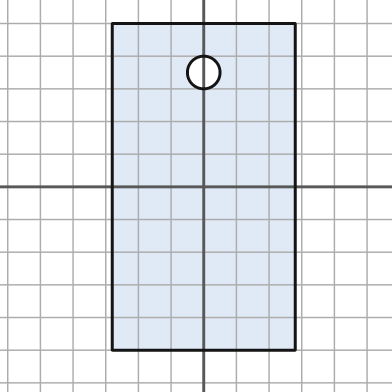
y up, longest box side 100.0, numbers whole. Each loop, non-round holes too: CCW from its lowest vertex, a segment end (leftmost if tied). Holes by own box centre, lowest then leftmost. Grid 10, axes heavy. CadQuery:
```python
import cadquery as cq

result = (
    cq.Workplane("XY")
    .moveTo(-28.0, -50.0)
    .lineTo(28.0, -50.0)
    .lineTo(28.0, 50.0)
    .lineTo(-28.0, 50.0)
    .close()
    .moveTo(0.0, 35.0)
    .circle(5.0)
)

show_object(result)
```